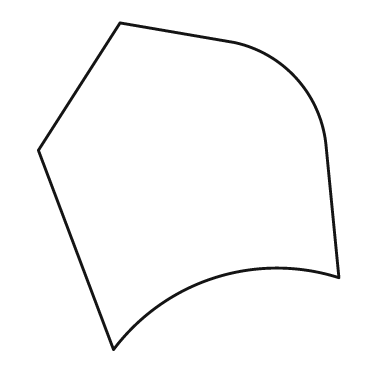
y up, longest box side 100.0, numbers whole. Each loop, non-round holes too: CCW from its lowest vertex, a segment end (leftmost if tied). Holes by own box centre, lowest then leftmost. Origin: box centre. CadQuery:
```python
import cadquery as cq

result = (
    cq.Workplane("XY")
    .moveTo(-23.0, -50.0)
    .threePointArc((8.0, -28.0), (46.0, -28.0))
    .lineTo(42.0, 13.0)
    .threePointArc((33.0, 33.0), (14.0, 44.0))
    .lineTo(-21.0, 50.0)
    .lineTo(-46.0, 11.0)
    .close()
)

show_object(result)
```